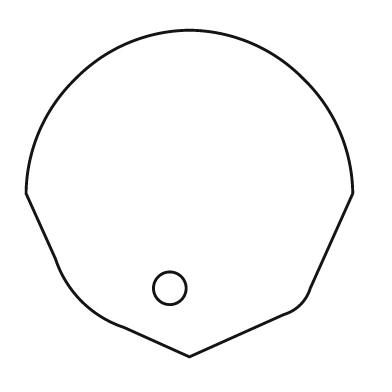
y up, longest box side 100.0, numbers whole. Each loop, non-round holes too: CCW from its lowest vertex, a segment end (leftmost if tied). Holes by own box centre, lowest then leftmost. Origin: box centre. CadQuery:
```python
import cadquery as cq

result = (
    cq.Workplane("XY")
    .moveTo(0.0, -50.0)
    .lineTo(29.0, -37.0)
    .threePointArc((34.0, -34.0), (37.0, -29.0))
    .lineTo(50.0, 0.0)
    .threePointArc((46.0, 19.0), (35.0, 35.0))
    .threePointArc((19.0, 46.0), (0.0, 50.0))
    .threePointArc((-19.0, 46.0), (-35.0, 35.0))
    .threePointArc((-46.0, 19.0), (-50.0, 0.0))
    .lineTo(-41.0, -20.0)
    .threePointArc((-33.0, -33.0), (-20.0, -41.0))
    .close()
    .moveTo(-6.0, -29.0)
    .circle(5.0)
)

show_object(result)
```